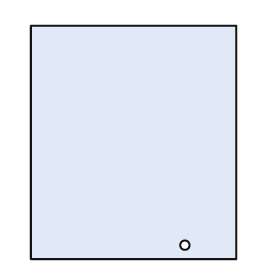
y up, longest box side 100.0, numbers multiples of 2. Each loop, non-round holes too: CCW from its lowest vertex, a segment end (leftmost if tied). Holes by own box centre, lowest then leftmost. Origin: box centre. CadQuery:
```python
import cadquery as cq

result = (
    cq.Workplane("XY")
    .moveTo(-44.0, -50.0)
    .lineTo(44.0, -50.0)
    .lineTo(44.0, 50.0)
    .lineTo(-44.0, 50.0)
    .close()
    .moveTo(22.0, -44.0)
    .circle(2.0)
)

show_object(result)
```